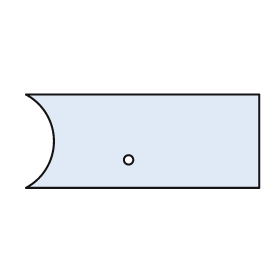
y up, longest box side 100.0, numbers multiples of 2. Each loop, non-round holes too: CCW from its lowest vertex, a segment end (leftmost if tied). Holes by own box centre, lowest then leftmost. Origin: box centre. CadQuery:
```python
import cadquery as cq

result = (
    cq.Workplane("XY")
    .moveTo(-50.0, -20.0)
    .lineTo(50.0, -20.0)
    .lineTo(50.0, 20.0)
    .lineTo(-50.0, 20.0)
    .threePointArc((-38.0, 0.0), (-50.0, -20.0))
    .close()
    .moveTo(-6.0, -8.0)
    .circle(2.0)
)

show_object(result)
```